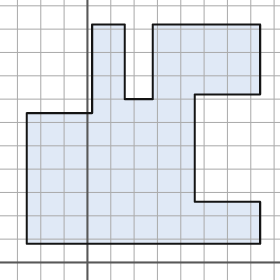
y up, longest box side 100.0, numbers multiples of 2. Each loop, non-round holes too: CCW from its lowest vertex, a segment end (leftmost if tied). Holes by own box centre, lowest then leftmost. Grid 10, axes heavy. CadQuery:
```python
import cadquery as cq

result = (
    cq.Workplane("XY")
    .moveTo(-26.0, 8.0)
    .lineTo(74.0, 8.0)
    .lineTo(74.0, 26.0)
    .lineTo(46.0, 26.0)
    .lineTo(46.0, 72.0)
    .lineTo(74.0, 72.0)
    .lineTo(74.0, 102.0)
    .lineTo(28.0, 102.0)
    .lineTo(28.0, 70.0)
    .lineTo(16.0, 70.0)
    .lineTo(16.0, 102.0)
    .lineTo(2.0, 102.0)
    .lineTo(2.0, 64.0)
    .lineTo(-26.0, 64.0)
    .close()
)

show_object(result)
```